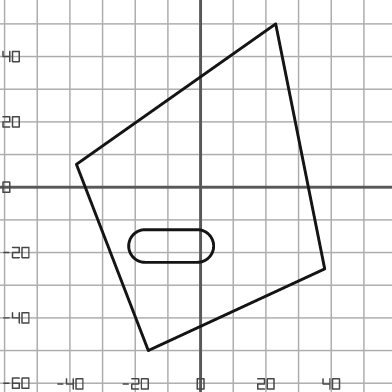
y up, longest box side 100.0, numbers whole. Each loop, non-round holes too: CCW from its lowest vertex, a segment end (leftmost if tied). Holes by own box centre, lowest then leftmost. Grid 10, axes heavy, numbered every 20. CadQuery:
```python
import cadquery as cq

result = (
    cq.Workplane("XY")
    .moveTo(-16.0, -50.0)
    .lineTo(38.0, -25.0)
    .lineTo(23.0, 50.0)
    .lineTo(-38.0, 7.0)
    .close()
    .moveTo(-17.0, -23.0)
    .lineTo(-1.0, -23.0)
    .threePointArc((4.0, -18.0), (-1.0, -13.0))
    .lineTo(-17.0, -13.0)
    .threePointArc((-22.0, -18.0), (-17.0, -23.0))
    .close()
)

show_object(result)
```